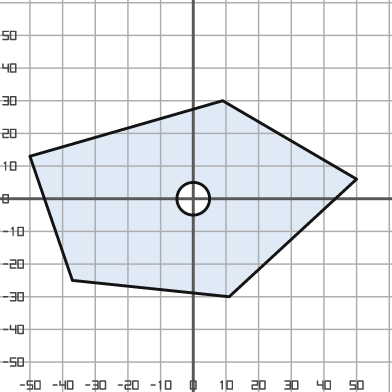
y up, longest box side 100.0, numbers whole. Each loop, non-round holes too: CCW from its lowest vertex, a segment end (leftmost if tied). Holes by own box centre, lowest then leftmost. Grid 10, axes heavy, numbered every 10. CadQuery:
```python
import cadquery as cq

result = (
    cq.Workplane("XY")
    .moveTo(11.0, -30.0)
    .lineTo(50.0, 6.0)
    .lineTo(9.0, 30.0)
    .lineTo(-50.0, 13.0)
    .lineTo(-37.0, -25.0)
    .close()
    .moveTo(0.0, 0.0)
    .circle(5.0)
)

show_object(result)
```